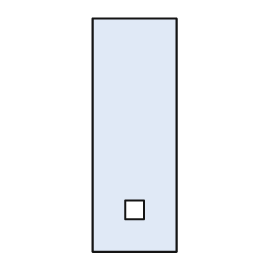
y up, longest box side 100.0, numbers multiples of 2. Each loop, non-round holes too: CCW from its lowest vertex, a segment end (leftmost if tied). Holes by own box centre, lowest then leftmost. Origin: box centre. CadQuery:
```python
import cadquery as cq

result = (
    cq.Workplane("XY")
    .moveTo(-18.0, -50.0)
    .lineTo(18.0, -50.0)
    .lineTo(18.0, 50.0)
    .lineTo(-18.0, 50.0)
    .close()
    .moveTo(-4.0, -36.0)
    .lineTo(4.0, -36.0)
    .lineTo(4.0, -28.0)
    .lineTo(-4.0, -28.0)
    .close()
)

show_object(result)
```